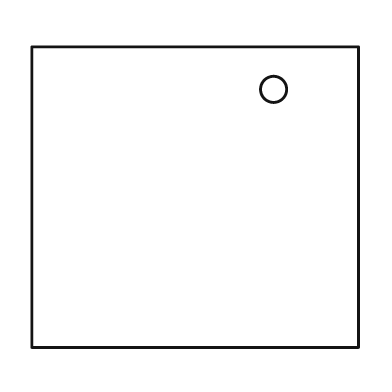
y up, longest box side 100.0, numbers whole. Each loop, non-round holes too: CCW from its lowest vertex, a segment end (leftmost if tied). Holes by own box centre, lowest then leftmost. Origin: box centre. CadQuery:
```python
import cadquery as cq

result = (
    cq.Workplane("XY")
    .moveTo(-50.0, -46.0)
    .lineTo(50.0, -46.0)
    .lineTo(50.0, 46.0)
    .lineTo(-50.0, 46.0)
    .close()
    .moveTo(24.0, 33.0)
    .circle(4.0)
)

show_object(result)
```